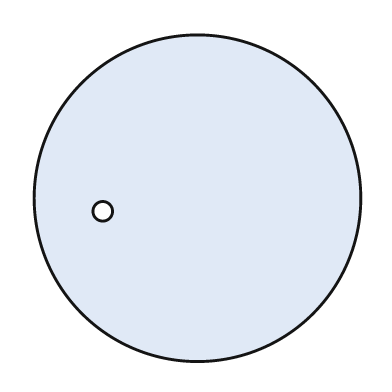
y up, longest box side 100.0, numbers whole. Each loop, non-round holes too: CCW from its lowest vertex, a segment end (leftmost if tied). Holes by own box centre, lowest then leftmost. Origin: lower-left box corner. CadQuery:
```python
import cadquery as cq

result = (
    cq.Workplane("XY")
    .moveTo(50.0, 50.0)
    .circle(50.0)
    .moveTo(21.0, 46.0)
    .circle(3.0)
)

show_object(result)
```